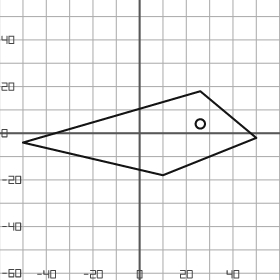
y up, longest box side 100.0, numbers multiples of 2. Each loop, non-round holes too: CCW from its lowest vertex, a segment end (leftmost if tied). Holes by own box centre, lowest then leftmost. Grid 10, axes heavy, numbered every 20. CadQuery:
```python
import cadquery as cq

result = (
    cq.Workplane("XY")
    .moveTo(10.0, -18.0)
    .lineTo(50.0, -2.0)
    .lineTo(26.0, 18.0)
    .lineTo(-50.0, -4.0)
    .close()
    .moveTo(26.0, 4.0)
    .circle(2.0)
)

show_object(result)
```